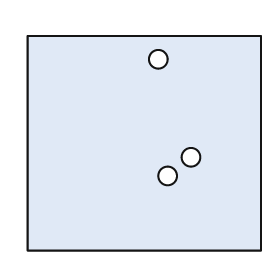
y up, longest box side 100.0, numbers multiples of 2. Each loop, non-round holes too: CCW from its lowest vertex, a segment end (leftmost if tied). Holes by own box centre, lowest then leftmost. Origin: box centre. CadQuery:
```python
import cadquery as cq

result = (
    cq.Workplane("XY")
    .moveTo(-50.0, -46.0)
    .lineTo(50.0, -46.0)
    .lineTo(50.0, 46.0)
    .lineTo(-50.0, 46.0)
    .close()
    .moveTo(10.0, -14.0)
    .circle(4.0)
    .moveTo(20.0, -6.0)
    .circle(4.0)
    .moveTo(6.0, 36.0)
    .circle(4.0)
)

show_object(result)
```